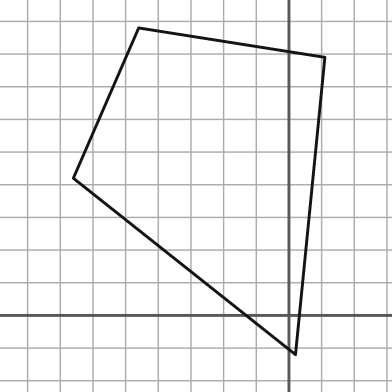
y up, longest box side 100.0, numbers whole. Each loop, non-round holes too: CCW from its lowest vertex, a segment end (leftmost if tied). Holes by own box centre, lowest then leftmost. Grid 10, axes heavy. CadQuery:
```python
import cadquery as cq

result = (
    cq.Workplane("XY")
    .moveTo(2.0, -12.0)
    .lineTo(11.0, 79.0)
    .lineTo(-46.0, 88.0)
    .lineTo(-66.0, 42.0)
    .close()
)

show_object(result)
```